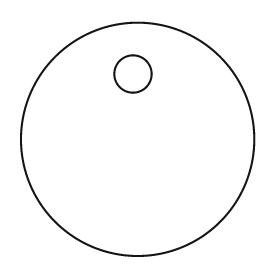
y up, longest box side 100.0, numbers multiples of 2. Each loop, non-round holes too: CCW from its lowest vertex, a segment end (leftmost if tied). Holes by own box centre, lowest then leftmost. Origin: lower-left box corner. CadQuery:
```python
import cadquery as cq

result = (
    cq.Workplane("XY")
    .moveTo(50.0, 50.0)
    .circle(50.0)
    .moveTo(48.0, 78.0)
    .circle(8.0)
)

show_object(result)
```